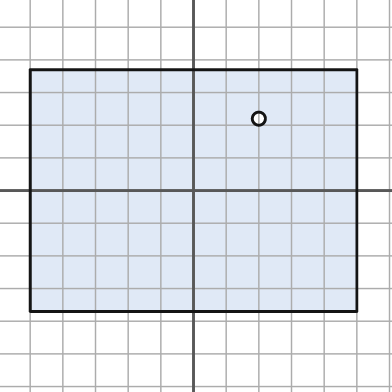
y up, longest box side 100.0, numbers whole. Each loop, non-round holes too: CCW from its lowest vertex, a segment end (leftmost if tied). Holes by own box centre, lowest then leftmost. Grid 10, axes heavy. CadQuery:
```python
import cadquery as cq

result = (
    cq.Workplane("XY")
    .moveTo(-50.0, -37.0)
    .lineTo(50.0, -37.0)
    .lineTo(50.0, 37.0)
    .lineTo(-50.0, 37.0)
    .close()
    .moveTo(20.0, 22.0)
    .circle(2.0)
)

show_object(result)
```